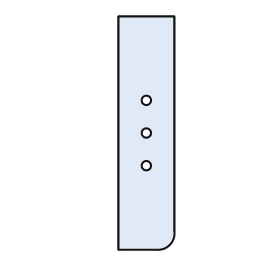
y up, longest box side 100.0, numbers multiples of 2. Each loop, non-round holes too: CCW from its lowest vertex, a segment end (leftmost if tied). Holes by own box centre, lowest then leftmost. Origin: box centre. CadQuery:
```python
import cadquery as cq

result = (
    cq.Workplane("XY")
    .moveTo(-12.0, -50.0)
    .lineTo(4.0, -50.0)
    .threePointArc((10.0, -48.0), (12.0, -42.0))
    .lineTo(12.0, 50.0)
    .lineTo(-12.0, 50.0)
    .close()
    .moveTo(0.0, -14.0)
    .circle(2.0)
    .moveTo(0.0, 0.0)
    .circle(2.0)
    .moveTo(0.0, 14.0)
    .circle(2.0)
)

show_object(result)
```